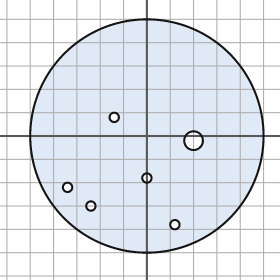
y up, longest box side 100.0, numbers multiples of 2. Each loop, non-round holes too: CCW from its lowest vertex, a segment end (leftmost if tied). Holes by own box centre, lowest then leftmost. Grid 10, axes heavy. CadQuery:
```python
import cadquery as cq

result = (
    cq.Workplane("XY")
    .moveTo(0.0, 0.0)
    .circle(50.0)
    .moveTo(12.0, -38.0)
    .circle(2.0)
    .moveTo(-24.0, -30.0)
    .circle(2.0)
    .moveTo(-34.0, -22.0)
    .circle(2.0)
    .moveTo(0.0, -18.0)
    .circle(2.0)
    .moveTo(20.0, -2.0)
    .circle(4.0)
    .moveTo(-14.0, 8.0)
    .circle(2.0)
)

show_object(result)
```